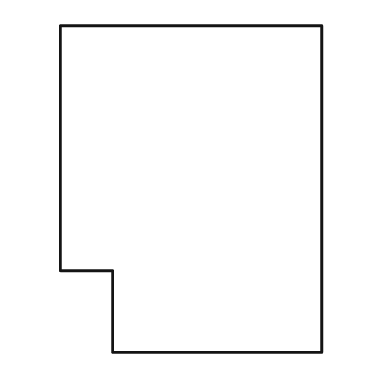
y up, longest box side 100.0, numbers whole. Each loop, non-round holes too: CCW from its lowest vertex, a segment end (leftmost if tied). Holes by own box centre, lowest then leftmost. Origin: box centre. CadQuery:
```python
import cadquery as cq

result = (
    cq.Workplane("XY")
    .moveTo(-24.0, -50.0)
    .lineTo(40.0, -50.0)
    .lineTo(40.0, 50.0)
    .lineTo(-40.0, 50.0)
    .lineTo(-40.0, -25.0)
    .lineTo(-24.0, -25.0)
    .close()
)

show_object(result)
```